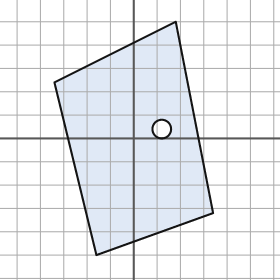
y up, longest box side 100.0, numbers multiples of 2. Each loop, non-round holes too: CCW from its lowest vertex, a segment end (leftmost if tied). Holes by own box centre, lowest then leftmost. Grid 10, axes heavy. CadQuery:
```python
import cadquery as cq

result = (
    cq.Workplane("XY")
    .moveTo(-16.0, -50.0)
    .lineTo(34.0, -32.0)
    .lineTo(18.0, 50.0)
    .lineTo(-34.0, 24.0)
    .close()
    .moveTo(12.0, 4.0)
    .circle(4.0)
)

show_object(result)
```